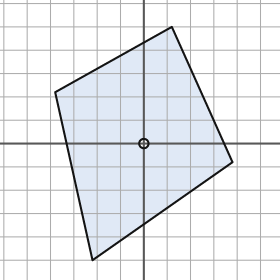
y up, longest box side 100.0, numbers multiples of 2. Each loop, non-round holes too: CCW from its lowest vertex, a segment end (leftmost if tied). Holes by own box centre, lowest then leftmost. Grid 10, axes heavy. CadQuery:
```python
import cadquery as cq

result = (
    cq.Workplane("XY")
    .moveTo(-22.0, -50.0)
    .lineTo(38.0, -8.0)
    .lineTo(12.0, 50.0)
    .lineTo(-38.0, 22.0)
    .close()
    .moveTo(0.0, 0.0)
    .circle(2.0)
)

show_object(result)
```